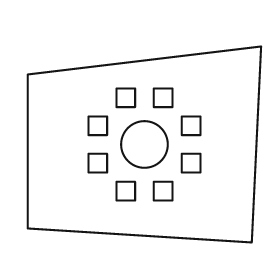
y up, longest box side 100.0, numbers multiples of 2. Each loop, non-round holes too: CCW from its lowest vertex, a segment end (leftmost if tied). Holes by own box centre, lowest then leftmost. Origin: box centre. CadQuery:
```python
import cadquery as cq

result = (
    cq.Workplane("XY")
    .moveTo(46.0, -42.0)
    .lineTo(50.0, 42.0)
    .lineTo(-50.0, 30.0)
    .lineTo(-50.0, -36.0)
    .close()
    .moveTo(-12.0, -24.0)
    .lineTo(-4.0, -24.0)
    .lineTo(-4.0, -16.0)
    .lineTo(-12.0, -16.0)
    .close()
    .moveTo(4.0, -24.0)
    .lineTo(12.0, -24.0)
    .lineTo(12.0, -16.0)
    .lineTo(4.0, -16.0)
    .close()
    .moveTo(-24.0, -12.0)
    .lineTo(-16.0, -12.0)
    .lineTo(-16.0, -4.0)
    .lineTo(-24.0, -4.0)
    .close()
    .moveTo(16.0, -12.0)
    .lineTo(24.0, -12.0)
    .lineTo(24.0, -4.0)
    .lineTo(16.0, -4.0)
    .close()
    .moveTo(0.0, 0.0)
    .circle(10.0)
    .moveTo(-24.0, 4.0)
    .lineTo(-16.0, 4.0)
    .lineTo(-16.0, 12.0)
    .lineTo(-24.0, 12.0)
    .close()
    .moveTo(16.0, 4.0)
    .lineTo(24.0, 4.0)
    .lineTo(24.0, 12.0)
    .lineTo(16.0, 12.0)
    .close()
    .moveTo(-12.0, 16.0)
    .lineTo(-4.0, 16.0)
    .lineTo(-4.0, 24.0)
    .lineTo(-12.0, 24.0)
    .close()
    .moveTo(4.0, 16.0)
    .lineTo(12.0, 16.0)
    .lineTo(12.0, 24.0)
    .lineTo(4.0, 24.0)
    .close()
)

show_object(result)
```